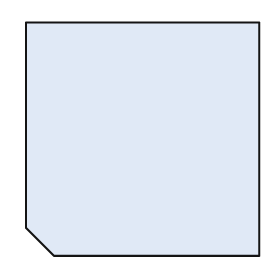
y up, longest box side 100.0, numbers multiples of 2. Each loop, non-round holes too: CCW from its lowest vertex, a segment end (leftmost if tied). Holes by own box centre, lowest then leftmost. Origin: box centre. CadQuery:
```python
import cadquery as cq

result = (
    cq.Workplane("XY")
    .moveTo(-38.0, -50.0)
    .lineTo(50.0, -50.0)
    .lineTo(50.0, 50.0)
    .lineTo(-50.0, 50.0)
    .lineTo(-50.0, -38.0)
    .close()
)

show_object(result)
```